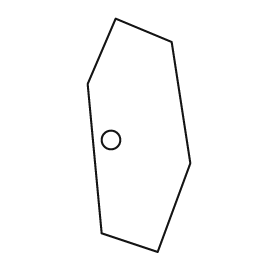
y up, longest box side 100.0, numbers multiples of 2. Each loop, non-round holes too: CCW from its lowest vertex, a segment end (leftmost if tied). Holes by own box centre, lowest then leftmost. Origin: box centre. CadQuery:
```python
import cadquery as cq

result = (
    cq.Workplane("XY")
    .moveTo(8.0, -50.0)
    .lineTo(22.0, -12.0)
    .lineTo(14.0, 40.0)
    .lineTo(-10.0, 50.0)
    .lineTo(-22.0, 22.0)
    .lineTo(-16.0, -42.0)
    .close()
    .moveTo(-12.0, -2.0)
    .circle(4.0)
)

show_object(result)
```